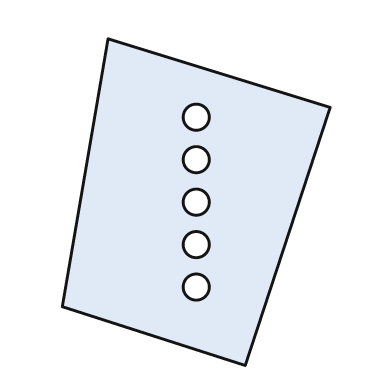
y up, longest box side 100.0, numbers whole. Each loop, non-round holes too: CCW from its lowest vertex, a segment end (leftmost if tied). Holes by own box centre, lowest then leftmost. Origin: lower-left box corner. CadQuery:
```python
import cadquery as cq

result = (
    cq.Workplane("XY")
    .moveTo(56.0, 0.0)
    .lineTo(82.0, 79.0)
    .lineTo(14.0, 100.0)
    .lineTo(0.0, 18.0)
    .close()
    .moveTo(41.0, 24.0)
    .circle(4.0)
    .moveTo(41.0, 37.0)
    .circle(4.0)
    .moveTo(41.0, 50.0)
    .circle(4.0)
    .moveTo(41.0, 63.0)
    .circle(4.0)
    .moveTo(41.0, 76.0)
    .circle(4.0)
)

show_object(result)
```